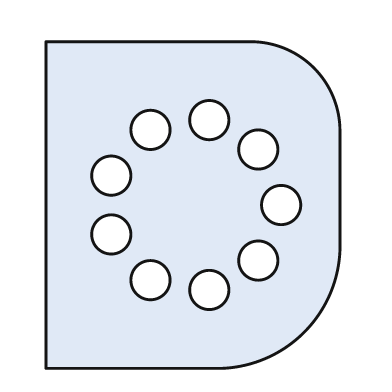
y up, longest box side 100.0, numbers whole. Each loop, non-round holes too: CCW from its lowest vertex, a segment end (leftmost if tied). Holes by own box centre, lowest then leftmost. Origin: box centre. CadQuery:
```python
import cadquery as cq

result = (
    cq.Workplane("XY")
    .moveTo(-45.0, -50.0)
    .lineTo(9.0, -50.0)
    .threePointArc((34.0, -39.0), (45.0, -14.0))
    .lineTo(45.0, 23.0)
    .threePointArc((37.0, 42.0), (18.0, 50.0))
    .lineTo(-45.0, 50.0)
    .close()
    .moveTo(5.0, -26.0)
    .circle(6.0)
    .moveTo(-13.0, -23.0)
    .circle(6.0)
    .moveTo(20.0, -17.0)
    .circle(6.0)
    .moveTo(-25.0, -9.0)
    .circle(6.0)
    .moveTo(27.0, 0.0)
    .circle(6.0)
    .moveTo(-25.0, 9.0)
    .circle(6.0)
    .moveTo(20.0, 17.0)
    .circle(6.0)
    .moveTo(-13.0, 23.0)
    .circle(6.0)
    .moveTo(5.0, 26.0)
    .circle(6.0)
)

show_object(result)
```